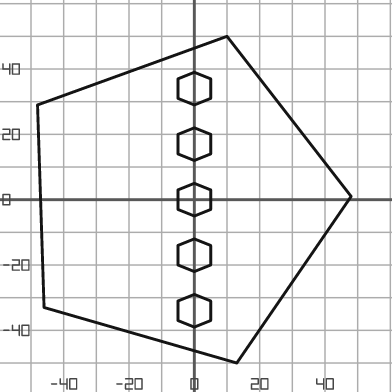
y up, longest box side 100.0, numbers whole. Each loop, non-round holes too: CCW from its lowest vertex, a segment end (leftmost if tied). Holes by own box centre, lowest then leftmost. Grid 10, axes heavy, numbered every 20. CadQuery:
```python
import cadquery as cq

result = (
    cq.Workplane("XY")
    .moveTo(13.0, -50.0)
    .lineTo(48.0, 1.0)
    .lineTo(10.0, 50.0)
    .lineTo(-48.0, 29.0)
    .lineTo(-46.0, -33.0)
    .close()
    .moveTo(0.0, -39.0)
    .lineTo(5.0, -37.0)
    .lineTo(5.0, -31.0)
    .lineTo(0.0, -29.0)
    .lineTo(-5.0, -31.0)
    .lineTo(-5.0, -37.0)
    .close()
    .moveTo(0.0, -22.0)
    .lineTo(5.0, -20.0)
    .lineTo(5.0, -14.0)
    .lineTo(0.0, -12.0)
    .lineTo(-5.0, -14.0)
    .lineTo(-5.0, -20.0)
    .close()
    .moveTo(0.0, -5.0)
    .lineTo(5.0, -3.0)
    .lineTo(5.0, 3.0)
    .lineTo(0.0, 5.0)
    .lineTo(-5.0, 3.0)
    .lineTo(-5.0, -3.0)
    .close()
    .moveTo(0.0, 12.0)
    .lineTo(5.0, 14.0)
    .lineTo(5.0, 20.0)
    .lineTo(0.0, 22.0)
    .lineTo(-5.0, 20.0)
    .lineTo(-5.0, 14.0)
    .close()
    .moveTo(0.0, 29.0)
    .lineTo(5.0, 31.0)
    .lineTo(5.0, 37.0)
    .lineTo(0.0, 39.0)
    .lineTo(-5.0, 37.0)
    .lineTo(-5.0, 31.0)
    .close()
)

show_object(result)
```